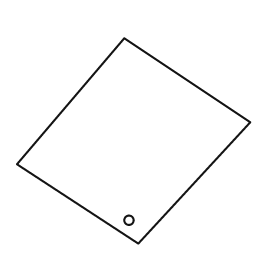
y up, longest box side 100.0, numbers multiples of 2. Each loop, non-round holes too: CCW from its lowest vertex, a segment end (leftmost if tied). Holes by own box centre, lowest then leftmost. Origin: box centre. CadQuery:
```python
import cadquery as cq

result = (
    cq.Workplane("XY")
    .moveTo(2.0, -44.0)
    .lineTo(50.0, 8.0)
    .lineTo(-4.0, 44.0)
    .lineTo(-50.0, -10.0)
    .close()
    .moveTo(-2.0, -34.0)
    .circle(2.0)
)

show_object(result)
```